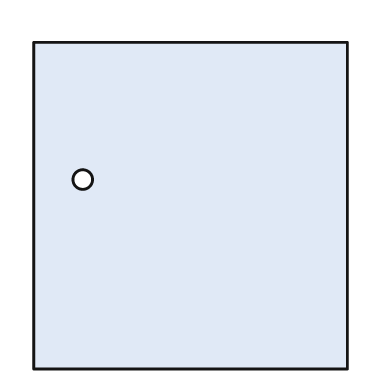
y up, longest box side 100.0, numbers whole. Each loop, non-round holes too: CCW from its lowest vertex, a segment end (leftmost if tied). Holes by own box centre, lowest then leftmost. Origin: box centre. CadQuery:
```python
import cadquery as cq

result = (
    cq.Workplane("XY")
    .moveTo(-48.0, -50.0)
    .lineTo(48.0, -50.0)
    .lineTo(48.0, 50.0)
    .lineTo(-48.0, 50.0)
    .close()
    .moveTo(-33.0, 8.0)
    .circle(3.0)
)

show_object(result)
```